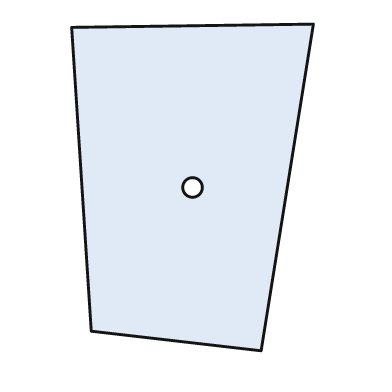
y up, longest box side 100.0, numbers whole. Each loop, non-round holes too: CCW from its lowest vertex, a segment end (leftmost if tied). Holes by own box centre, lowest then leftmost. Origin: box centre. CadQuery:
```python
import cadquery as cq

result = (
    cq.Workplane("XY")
    .moveTo(21.0, -50.0)
    .lineTo(37.0, 50.0)
    .lineTo(-37.0, 49.0)
    .lineTo(-31.0, -44.0)
    .close()
    .moveTo(0.0, 0.0)
    .circle(3.0)
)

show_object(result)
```